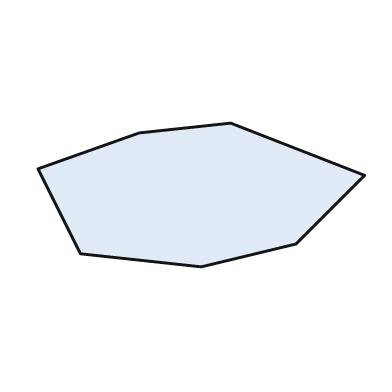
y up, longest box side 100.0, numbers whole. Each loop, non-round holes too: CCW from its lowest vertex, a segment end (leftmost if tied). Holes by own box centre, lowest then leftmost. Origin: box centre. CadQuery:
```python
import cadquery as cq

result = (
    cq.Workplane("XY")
    .moveTo(0.0, -22.0)
    .lineTo(29.0, -15.0)
    .lineTo(50.0, 6.0)
    .lineTo(9.0, 22.0)
    .lineTo(-19.0, 19.0)
    .lineTo(-50.0, 8.0)
    .lineTo(-37.0, -18.0)
    .close()
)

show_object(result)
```